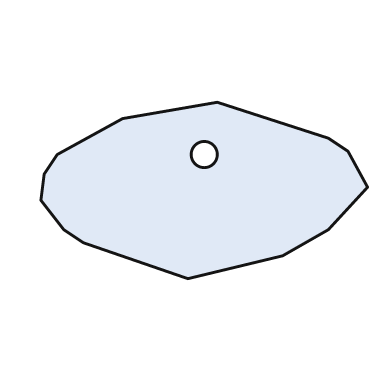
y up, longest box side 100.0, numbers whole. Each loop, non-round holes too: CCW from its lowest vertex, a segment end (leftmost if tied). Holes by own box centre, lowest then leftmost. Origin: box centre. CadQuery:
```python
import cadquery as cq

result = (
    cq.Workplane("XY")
    .moveTo(-5.0, -27.0)
    .lineTo(24.0, -20.0)
    .lineTo(38.0, -12.0)
    .lineTo(50.0, 1.0)
    .lineTo(44.0, 12.0)
    .lineTo(38.0, 16.0)
    .lineTo(4.0, 27.0)
    .lineTo(-25.0, 22.0)
    .lineTo(-45.0, 11.0)
    .lineTo(-49.0, 5.0)
    .lineTo(-50.0, -3.0)
    .lineTo(-43.0, -12.0)
    .lineTo(-37.0, -16.0)
    .close()
    .moveTo(0.0, 11.0)
    .circle(4.0)
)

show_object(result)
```